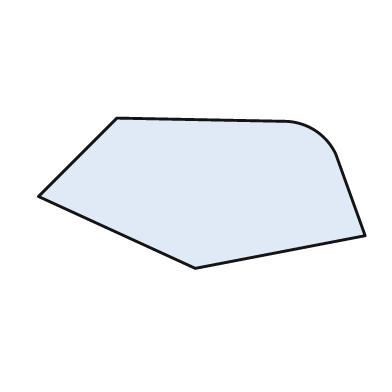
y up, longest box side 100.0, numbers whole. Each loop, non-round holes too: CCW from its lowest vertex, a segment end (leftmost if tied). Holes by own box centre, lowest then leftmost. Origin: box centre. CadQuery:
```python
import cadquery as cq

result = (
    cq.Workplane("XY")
    .moveTo(-2.0, -23.0)
    .lineTo(50.0, -13.0)
    .lineTo(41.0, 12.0)
    .threePointArc((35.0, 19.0), (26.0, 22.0))
    .lineTo(-26.0, 23.0)
    .lineTo(-50.0, -1.0)
    .close()
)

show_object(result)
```